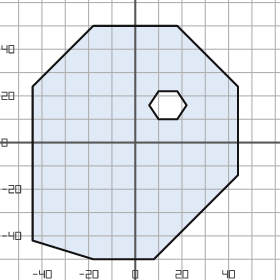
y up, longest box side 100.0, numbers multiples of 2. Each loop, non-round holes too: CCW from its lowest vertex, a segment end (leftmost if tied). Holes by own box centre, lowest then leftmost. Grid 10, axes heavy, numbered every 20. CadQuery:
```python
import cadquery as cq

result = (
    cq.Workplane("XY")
    .moveTo(-18.0, -50.0)
    .lineTo(8.0, -50.0)
    .lineTo(44.0, -14.0)
    .lineTo(44.0, 24.0)
    .lineTo(18.0, 50.0)
    .lineTo(-18.0, 50.0)
    .lineTo(-44.0, 24.0)
    .lineTo(-44.0, -42.0)
    .close()
    .moveTo(10.0, 10.0)
    .lineTo(18.0, 10.0)
    .lineTo(22.0, 16.0)
    .lineTo(18.0, 22.0)
    .lineTo(10.0, 22.0)
    .lineTo(6.0, 16.0)
    .close()
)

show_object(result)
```